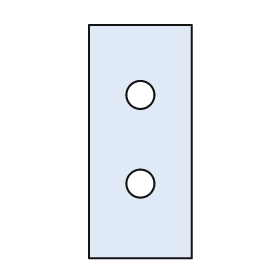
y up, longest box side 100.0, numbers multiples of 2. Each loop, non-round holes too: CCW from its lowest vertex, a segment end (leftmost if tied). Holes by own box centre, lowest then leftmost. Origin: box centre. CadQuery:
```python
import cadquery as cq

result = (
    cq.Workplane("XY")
    .moveTo(-22.0, -50.0)
    .lineTo(22.0, -50.0)
    .lineTo(22.0, 50.0)
    .lineTo(-22.0, 50.0)
    .close()
    .moveTo(0.0, -18.0)
    .circle(6.0)
    .moveTo(0.0, 20.0)
    .circle(6.0)
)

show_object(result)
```